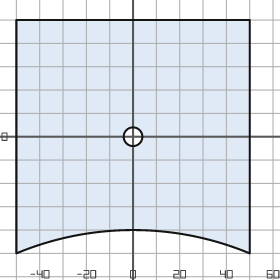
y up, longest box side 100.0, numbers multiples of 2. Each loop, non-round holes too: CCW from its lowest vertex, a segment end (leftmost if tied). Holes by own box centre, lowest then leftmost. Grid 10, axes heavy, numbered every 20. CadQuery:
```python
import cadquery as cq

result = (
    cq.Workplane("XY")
    .moveTo(-50.0, -50.0)
    .threePointArc((0.0, -40.0), (50.0, -50.0))
    .lineTo(50.0, 50.0)
    .lineTo(-50.0, 50.0)
    .close()
    .moveTo(0.0, 0.0)
    .circle(4.0)
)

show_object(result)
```